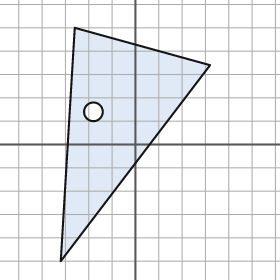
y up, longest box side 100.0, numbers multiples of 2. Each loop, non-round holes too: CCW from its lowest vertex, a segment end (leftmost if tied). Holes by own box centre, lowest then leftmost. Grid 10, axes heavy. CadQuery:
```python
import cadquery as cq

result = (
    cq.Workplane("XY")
    .moveTo(-32.0, -50.0)
    .lineTo(32.0, 34.0)
    .lineTo(-26.0, 50.0)
    .close()
    .moveTo(-18.0, 14.0)
    .circle(4.0)
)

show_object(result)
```